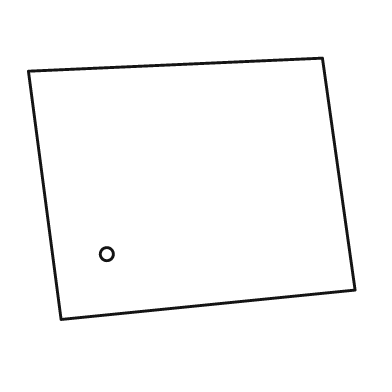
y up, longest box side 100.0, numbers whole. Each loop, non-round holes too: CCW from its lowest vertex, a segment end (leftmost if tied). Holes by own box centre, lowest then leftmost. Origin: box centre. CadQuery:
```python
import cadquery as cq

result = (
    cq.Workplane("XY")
    .moveTo(-40.0, -40.0)
    .lineTo(50.0, -31.0)
    .lineTo(40.0, 40.0)
    .lineTo(-50.0, 36.0)
    .close()
    .moveTo(-26.0, -20.0)
    .circle(2.0)
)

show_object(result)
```